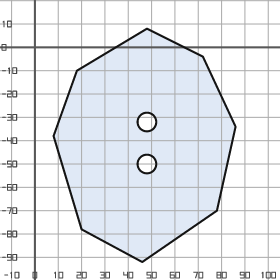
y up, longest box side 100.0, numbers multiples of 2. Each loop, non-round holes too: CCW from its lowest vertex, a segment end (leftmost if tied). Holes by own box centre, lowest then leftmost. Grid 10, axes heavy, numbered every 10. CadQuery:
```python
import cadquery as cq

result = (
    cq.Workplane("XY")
    .moveTo(46.0, -92.0)
    .lineTo(78.0, -70.0)
    .lineTo(86.0, -34.0)
    .lineTo(72.0, -4.0)
    .lineTo(48.0, 8.0)
    .lineTo(18.0, -10.0)
    .lineTo(8.0, -38.0)
    .lineTo(20.0, -78.0)
    .close()
    .moveTo(48.0, -50.0)
    .circle(4.0)
    .moveTo(48.0, -32.0)
    .circle(4.0)
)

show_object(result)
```